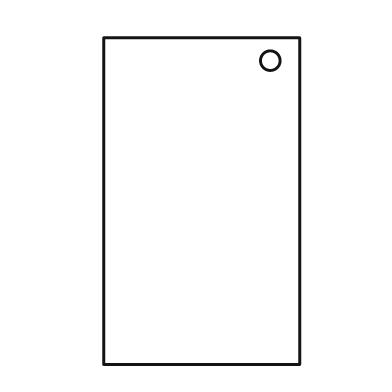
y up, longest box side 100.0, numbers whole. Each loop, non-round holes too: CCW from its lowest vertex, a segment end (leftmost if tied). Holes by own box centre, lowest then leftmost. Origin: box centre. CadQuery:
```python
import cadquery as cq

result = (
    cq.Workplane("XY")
    .moveTo(-30.0, -50.0)
    .lineTo(30.0, -50.0)
    .lineTo(30.0, 50.0)
    .lineTo(-30.0, 50.0)
    .close()
    .moveTo(21.0, 43.0)
    .circle(3.0)
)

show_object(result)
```